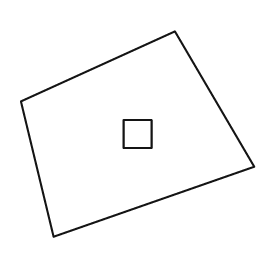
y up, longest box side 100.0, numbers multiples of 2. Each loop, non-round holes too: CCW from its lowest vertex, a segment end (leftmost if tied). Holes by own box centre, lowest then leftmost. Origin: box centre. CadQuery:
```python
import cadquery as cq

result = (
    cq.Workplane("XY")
    .moveTo(-36.0, -44.0)
    .lineTo(50.0, -14.0)
    .lineTo(16.0, 44.0)
    .lineTo(-50.0, 14.0)
    .close()
    .moveTo(-6.0, -6.0)
    .lineTo(6.0, -6.0)
    .lineTo(6.0, 6.0)
    .lineTo(-6.0, 6.0)
    .close()
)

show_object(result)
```